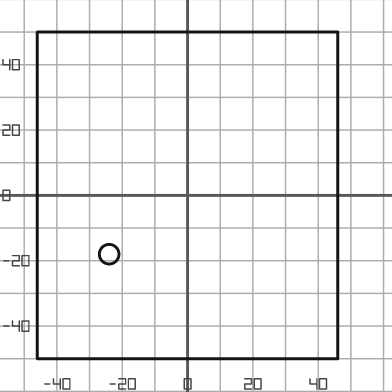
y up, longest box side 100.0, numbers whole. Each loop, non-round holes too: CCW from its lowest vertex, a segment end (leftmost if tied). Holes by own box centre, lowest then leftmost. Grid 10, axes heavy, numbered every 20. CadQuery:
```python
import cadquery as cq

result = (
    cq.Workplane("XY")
    .moveTo(-46.0, -50.0)
    .lineTo(46.0, -50.0)
    .lineTo(46.0, 50.0)
    .lineTo(-46.0, 50.0)
    .close()
    .moveTo(-24.0, -18.0)
    .circle(3.0)
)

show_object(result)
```